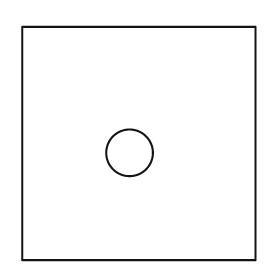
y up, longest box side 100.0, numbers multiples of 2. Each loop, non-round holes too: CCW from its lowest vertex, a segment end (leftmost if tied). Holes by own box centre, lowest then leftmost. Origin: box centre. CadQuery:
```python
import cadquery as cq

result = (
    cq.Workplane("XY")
    .moveTo(-50.0, -50.0)
    .lineTo(50.0, -50.0)
    .lineTo(50.0, 50.0)
    .lineTo(-50.0, 50.0)
    .close()
    .moveTo(-4.0, -4.0)
    .circle(10.0)
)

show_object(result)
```